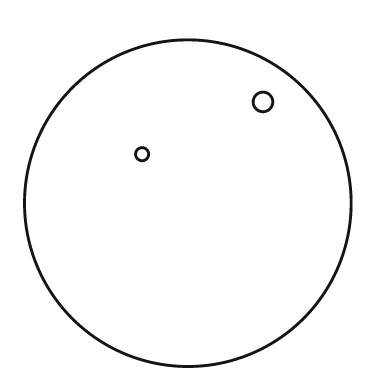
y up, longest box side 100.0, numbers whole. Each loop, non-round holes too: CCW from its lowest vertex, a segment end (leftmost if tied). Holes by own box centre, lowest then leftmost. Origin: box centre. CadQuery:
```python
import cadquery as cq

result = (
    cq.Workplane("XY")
    .moveTo(0.0, 0.0)
    .circle(50.0)
    .moveTo(-14.0, 15.0)
    .circle(2.0)
    .moveTo(23.0, 31.0)
    .circle(3.0)
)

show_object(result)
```